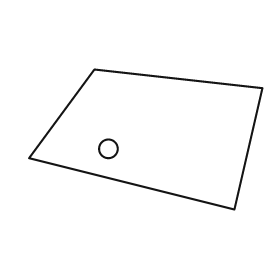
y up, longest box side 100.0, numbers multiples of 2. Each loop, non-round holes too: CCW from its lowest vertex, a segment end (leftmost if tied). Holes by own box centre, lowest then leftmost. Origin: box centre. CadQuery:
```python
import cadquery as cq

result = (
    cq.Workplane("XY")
    .moveTo(38.0, -30.0)
    .lineTo(50.0, 22.0)
    .lineTo(-22.0, 30.0)
    .lineTo(-50.0, -8.0)
    .close()
    .moveTo(-16.0, -4.0)
    .circle(4.0)
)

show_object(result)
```